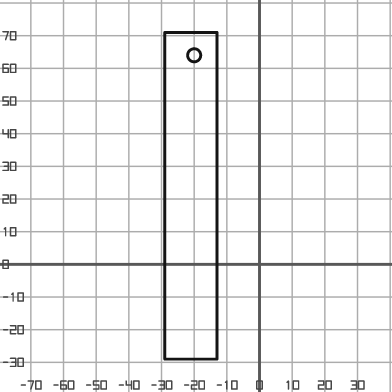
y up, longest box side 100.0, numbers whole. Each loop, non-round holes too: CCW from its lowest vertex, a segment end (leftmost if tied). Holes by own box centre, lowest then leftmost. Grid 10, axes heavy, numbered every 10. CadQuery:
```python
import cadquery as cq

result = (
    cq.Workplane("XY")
    .moveTo(-29.0, -29.0)
    .lineTo(-13.0, -29.0)
    .lineTo(-13.0, 71.0)
    .lineTo(-29.0, 71.0)
    .close()
    .moveTo(-20.0, 64.0)
    .circle(2.0)
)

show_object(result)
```